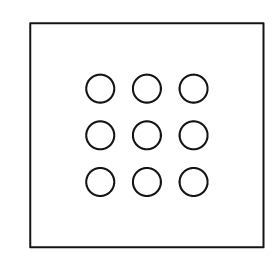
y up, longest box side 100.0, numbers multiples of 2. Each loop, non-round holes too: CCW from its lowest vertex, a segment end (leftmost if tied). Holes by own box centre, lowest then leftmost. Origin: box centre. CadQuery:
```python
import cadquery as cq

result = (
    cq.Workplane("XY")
    .moveTo(-50.0, -48.0)
    .lineTo(50.0, -48.0)
    .lineTo(50.0, 48.0)
    .lineTo(-50.0, 48.0)
    .close()
    .moveTo(-20.0, -20.0)
    .circle(6.0)
    .moveTo(0.0, -20.0)
    .circle(6.0)
    .moveTo(20.0, -20.0)
    .circle(6.0)
    .moveTo(-20.0, 0.0)
    .circle(6.0)
    .moveTo(0.0, 0.0)
    .circle(6.0)
    .moveTo(20.0, 0.0)
    .circle(6.0)
    .moveTo(-20.0, 20.0)
    .circle(6.0)
    .moveTo(0.0, 20.0)
    .circle(6.0)
    .moveTo(20.0, 20.0)
    .circle(6.0)
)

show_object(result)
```